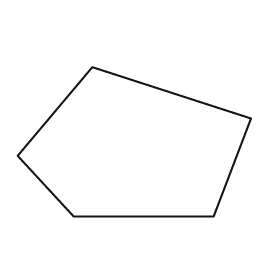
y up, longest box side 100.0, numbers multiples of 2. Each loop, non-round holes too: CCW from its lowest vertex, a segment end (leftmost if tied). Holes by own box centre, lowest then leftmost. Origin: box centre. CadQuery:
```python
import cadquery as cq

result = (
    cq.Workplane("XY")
    .moveTo(-26.0, -32.0)
    .lineTo(34.0, -32.0)
    .lineTo(50.0, 10.0)
    .lineTo(-18.0, 32.0)
    .lineTo(-50.0, -6.0)
    .close()
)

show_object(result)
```